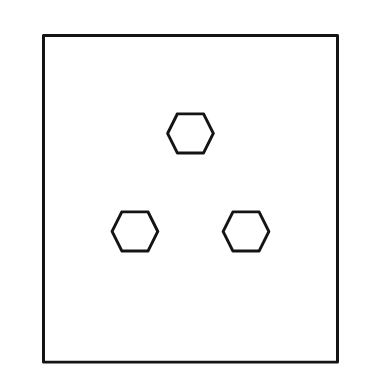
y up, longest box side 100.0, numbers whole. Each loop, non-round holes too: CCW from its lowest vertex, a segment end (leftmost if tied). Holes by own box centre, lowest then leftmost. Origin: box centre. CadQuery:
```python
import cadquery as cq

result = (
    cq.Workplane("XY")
    .moveTo(-45.0, -50.0)
    .lineTo(45.0, -50.0)
    .lineTo(45.0, 50.0)
    .lineTo(-45.0, 50.0)
    .close()
    .moveTo(-21.0, -16.0)
    .lineTo(-13.0, -16.0)
    .lineTo(-10.0, -10.0)
    .lineTo(-13.0, -4.0)
    .lineTo(-21.0, -4.0)
    .lineTo(-24.0, -10.0)
    .close()
    .moveTo(13.0, -16.0)
    .lineTo(21.0, -16.0)
    .lineTo(24.0, -10.0)
    .lineTo(21.0, -4.0)
    .lineTo(13.0, -4.0)
    .lineTo(10.0, -10.0)
    .close()
    .moveTo(-4.0, 14.0)
    .lineTo(4.0, 14.0)
    .lineTo(7.0, 20.0)
    .lineTo(4.0, 26.0)
    .lineTo(-4.0, 26.0)
    .lineTo(-7.0, 20.0)
    .close()
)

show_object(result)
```